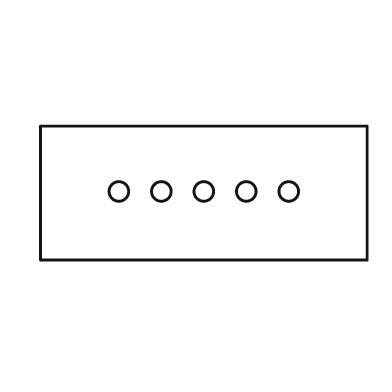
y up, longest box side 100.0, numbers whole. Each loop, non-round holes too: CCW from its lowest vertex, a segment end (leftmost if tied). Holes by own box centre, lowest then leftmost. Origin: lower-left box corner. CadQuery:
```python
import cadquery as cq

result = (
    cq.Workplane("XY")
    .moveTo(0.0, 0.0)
    .lineTo(100.0, 0.0)
    .lineTo(100.0, 41.0)
    .lineTo(0.0, 41.0)
    .close()
    .moveTo(24.0, 21.0)
    .circle(3.0)
    .moveTo(37.0, 21.0)
    .circle(3.0)
    .moveTo(50.0, 21.0)
    .circle(3.0)
    .moveTo(63.0, 21.0)
    .circle(3.0)
    .moveTo(76.0, 21.0)
    .circle(3.0)
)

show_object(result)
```